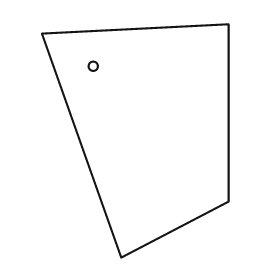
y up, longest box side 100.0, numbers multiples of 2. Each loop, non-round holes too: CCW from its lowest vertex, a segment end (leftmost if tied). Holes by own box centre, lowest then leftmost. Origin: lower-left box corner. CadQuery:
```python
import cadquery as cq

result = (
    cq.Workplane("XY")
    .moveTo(34.0, 0.0)
    .lineTo(80.0, 24.0)
    .lineTo(80.0, 100.0)
    .lineTo(0.0, 96.0)
    .close()
    .moveTo(22.0, 82.0)
    .circle(2.0)
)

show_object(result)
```